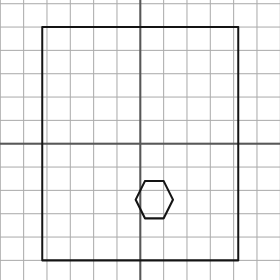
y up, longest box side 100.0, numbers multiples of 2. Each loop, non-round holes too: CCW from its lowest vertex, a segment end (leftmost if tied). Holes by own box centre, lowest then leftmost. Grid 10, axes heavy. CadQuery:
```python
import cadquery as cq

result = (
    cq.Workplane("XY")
    .moveTo(-42.0, -50.0)
    .lineTo(42.0, -50.0)
    .lineTo(42.0, 50.0)
    .lineTo(-42.0, 50.0)
    .close()
    .moveTo(2.0, -32.0)
    .lineTo(10.0, -32.0)
    .lineTo(14.0, -24.0)
    .lineTo(10.0, -16.0)
    .lineTo(2.0, -16.0)
    .lineTo(-2.0, -24.0)
    .close()
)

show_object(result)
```